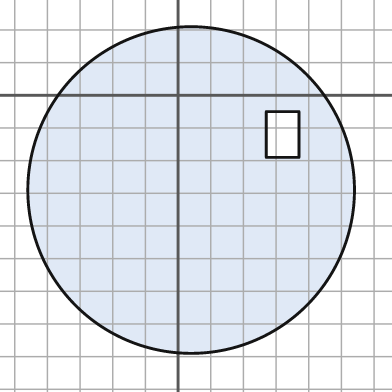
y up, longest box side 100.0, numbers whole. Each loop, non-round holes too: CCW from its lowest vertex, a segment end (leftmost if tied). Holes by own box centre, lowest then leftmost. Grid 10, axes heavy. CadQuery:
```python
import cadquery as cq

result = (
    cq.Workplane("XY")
    .moveTo(4.0, -29.0)
    .circle(50.0)
    .moveTo(27.0, -19.0)
    .lineTo(37.0, -19.0)
    .lineTo(37.0, -5.0)
    .lineTo(27.0, -5.0)
    .close()
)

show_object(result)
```